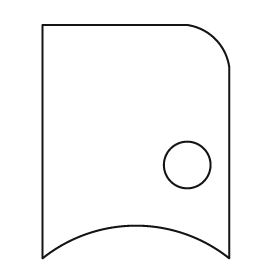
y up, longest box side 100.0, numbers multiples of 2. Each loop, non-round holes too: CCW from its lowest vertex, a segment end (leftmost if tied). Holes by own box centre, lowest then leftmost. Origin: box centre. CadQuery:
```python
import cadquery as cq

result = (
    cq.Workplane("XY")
    .moveTo(-40.0, -50.0)
    .threePointArc((0.0, -36.0), (40.0, -50.0))
    .lineTo(40.0, 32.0)
    .threePointArc((34.0, 44.0), (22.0, 50.0))
    .lineTo(-40.0, 50.0)
    .close()
    .moveTo(22.0, -10.0)
    .circle(10.0)
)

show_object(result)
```